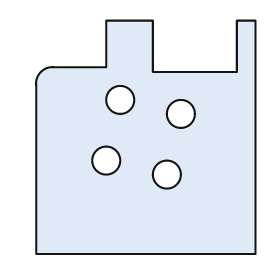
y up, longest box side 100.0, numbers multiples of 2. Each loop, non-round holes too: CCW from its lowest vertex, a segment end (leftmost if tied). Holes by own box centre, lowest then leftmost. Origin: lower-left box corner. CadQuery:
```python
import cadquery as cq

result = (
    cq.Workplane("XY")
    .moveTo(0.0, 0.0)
    .lineTo(94.0, 0.0)
    .lineTo(94.0, 100.0)
    .lineTo(86.0, 100.0)
    .lineTo(86.0, 78.0)
    .lineTo(50.0, 78.0)
    .lineTo(50.0, 100.0)
    .lineTo(30.0, 100.0)
    .lineTo(30.0, 80.0)
    .lineTo(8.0, 80.0)
    .threePointArc((2.0, 78.0), (0.0, 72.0))
    .close()
    .moveTo(56.0, 34.0)
    .circle(6.0)
    .moveTo(30.0, 40.0)
    .circle(6.0)
    .moveTo(62.0, 60.0)
    .circle(6.0)
    .moveTo(36.0, 66.0)
    .circle(6.0)
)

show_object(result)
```